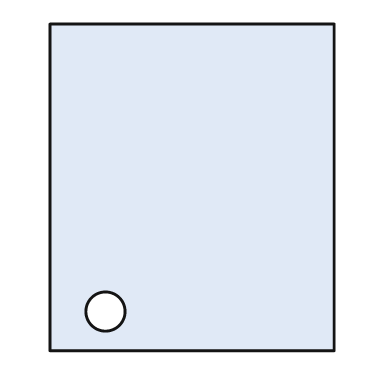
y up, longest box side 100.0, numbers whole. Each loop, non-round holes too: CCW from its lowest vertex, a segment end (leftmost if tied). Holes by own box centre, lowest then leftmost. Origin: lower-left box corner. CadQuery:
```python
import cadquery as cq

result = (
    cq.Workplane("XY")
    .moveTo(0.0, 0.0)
    .lineTo(87.0, 0.0)
    .lineTo(87.0, 100.0)
    .lineTo(0.0, 100.0)
    .close()
    .moveTo(17.0, 12.0)
    .circle(6.0)
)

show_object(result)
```